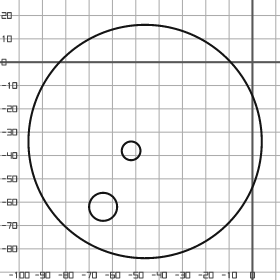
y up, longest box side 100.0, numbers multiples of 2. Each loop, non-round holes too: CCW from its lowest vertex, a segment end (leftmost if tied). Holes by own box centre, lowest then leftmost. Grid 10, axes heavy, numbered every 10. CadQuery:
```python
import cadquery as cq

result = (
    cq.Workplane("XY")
    .moveTo(-46.0, -34.0)
    .circle(50.0)
    .moveTo(-64.0, -62.0)
    .circle(6.0)
    .moveTo(-52.0, -38.0)
    .circle(4.0)
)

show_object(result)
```